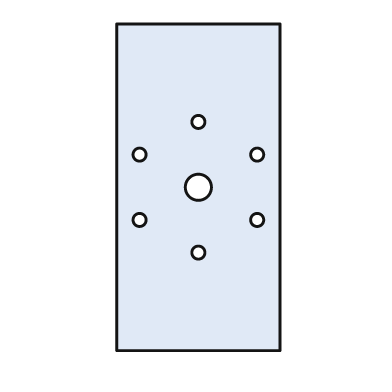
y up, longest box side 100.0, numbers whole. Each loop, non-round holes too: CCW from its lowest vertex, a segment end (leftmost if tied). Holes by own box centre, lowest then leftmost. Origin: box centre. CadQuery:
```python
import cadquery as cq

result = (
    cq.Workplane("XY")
    .moveTo(-25.0, -50.0)
    .lineTo(25.0, -50.0)
    .lineTo(25.0, 50.0)
    .lineTo(-25.0, 50.0)
    .close()
    .moveTo(0.0, -20.0)
    .circle(2.0)
    .moveTo(-18.0, -10.0)
    .circle(2.0)
    .moveTo(18.0, -10.0)
    .circle(2.0)
    .moveTo(0.0, 0.0)
    .circle(4.0)
    .moveTo(-18.0, 10.0)
    .circle(2.0)
    .moveTo(18.0, 10.0)
    .circle(2.0)
    .moveTo(0.0, 20.0)
    .circle(2.0)
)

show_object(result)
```